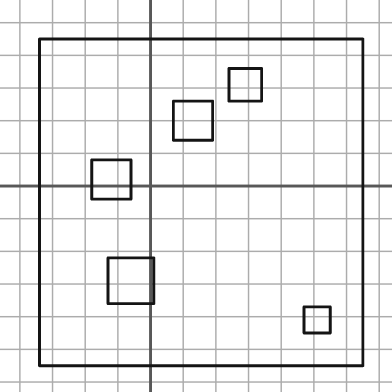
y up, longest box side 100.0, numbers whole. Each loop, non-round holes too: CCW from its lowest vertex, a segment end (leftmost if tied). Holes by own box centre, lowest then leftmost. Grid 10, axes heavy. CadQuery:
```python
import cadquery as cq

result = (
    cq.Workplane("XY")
    .moveTo(-34.0, -55.0)
    .lineTo(65.0, -55.0)
    .lineTo(65.0, 45.0)
    .lineTo(-34.0, 45.0)
    .close()
    .moveTo(47.0, -45.0)
    .lineTo(55.0, -45.0)
    .lineTo(55.0, -37.0)
    .lineTo(47.0, -37.0)
    .close()
    .moveTo(-13.0, -36.0)
    .lineTo(1.0, -36.0)
    .lineTo(1.0, -22.0)
    .lineTo(-13.0, -22.0)
    .close()
    .moveTo(-18.0, -4.0)
    .lineTo(-6.0, -4.0)
    .lineTo(-6.0, 8.0)
    .lineTo(-18.0, 8.0)
    .close()
    .moveTo(7.0, 14.0)
    .lineTo(19.0, 14.0)
    .lineTo(19.0, 26.0)
    .lineTo(7.0, 26.0)
    .close()
    .moveTo(24.0, 26.0)
    .lineTo(34.0, 26.0)
    .lineTo(34.0, 36.0)
    .lineTo(24.0, 36.0)
    .close()
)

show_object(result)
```